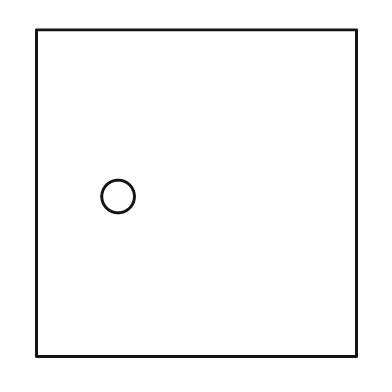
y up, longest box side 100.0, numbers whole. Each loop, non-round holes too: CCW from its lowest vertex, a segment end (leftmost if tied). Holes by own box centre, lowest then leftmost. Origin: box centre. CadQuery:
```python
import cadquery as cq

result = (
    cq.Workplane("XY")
    .moveTo(-49.0, -50.0)
    .lineTo(49.0, -50.0)
    .lineTo(49.0, 50.0)
    .lineTo(-49.0, 50.0)
    .close()
    .moveTo(-24.0, -1.0)
    .circle(5.0)
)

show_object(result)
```